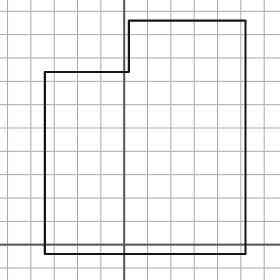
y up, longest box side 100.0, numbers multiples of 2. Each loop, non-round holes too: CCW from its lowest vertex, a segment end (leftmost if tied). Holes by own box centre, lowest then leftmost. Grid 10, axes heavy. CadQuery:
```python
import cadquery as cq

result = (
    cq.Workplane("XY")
    .moveTo(-34.0, -4.0)
    .lineTo(52.0, -4.0)
    .lineTo(52.0, 96.0)
    .lineTo(2.0, 96.0)
    .lineTo(2.0, 74.0)
    .lineTo(-34.0, 74.0)
    .close()
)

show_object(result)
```